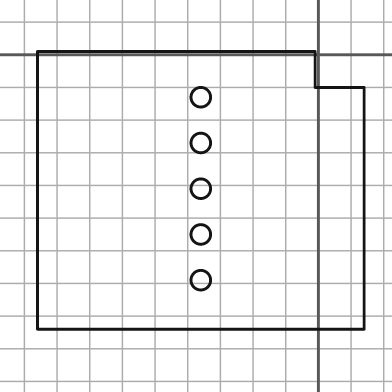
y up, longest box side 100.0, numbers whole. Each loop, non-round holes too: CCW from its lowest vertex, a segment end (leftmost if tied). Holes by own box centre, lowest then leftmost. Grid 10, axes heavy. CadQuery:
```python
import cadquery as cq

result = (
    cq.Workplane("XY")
    .moveTo(-86.0, -84.0)
    .lineTo(14.0, -84.0)
    .lineTo(14.0, -10.0)
    .lineTo(-1.0, -10.0)
    .lineTo(-1.0, 1.0)
    .lineTo(-86.0, 1.0)
    .close()
    .moveTo(-36.0, -69.0)
    .circle(3.0)
    .moveTo(-36.0, -55.0)
    .circle(3.0)
    .moveTo(-36.0, -41.0)
    .circle(3.0)
    .moveTo(-36.0, -27.0)
    .circle(3.0)
    .moveTo(-36.0, -13.0)
    .circle(3.0)
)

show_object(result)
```